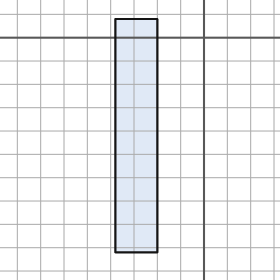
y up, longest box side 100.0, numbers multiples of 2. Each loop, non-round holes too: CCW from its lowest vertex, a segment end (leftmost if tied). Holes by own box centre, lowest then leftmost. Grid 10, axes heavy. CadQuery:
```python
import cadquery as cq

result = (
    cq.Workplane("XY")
    .moveTo(-38.0, -92.0)
    .lineTo(-20.0, -92.0)
    .lineTo(-20.0, 8.0)
    .lineTo(-38.0, 8.0)
    .close()
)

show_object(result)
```